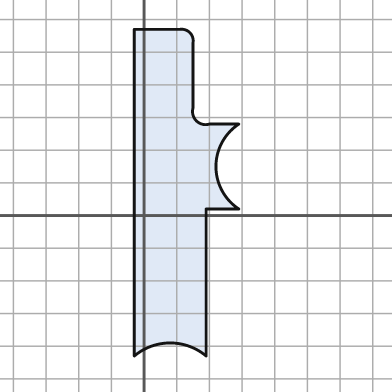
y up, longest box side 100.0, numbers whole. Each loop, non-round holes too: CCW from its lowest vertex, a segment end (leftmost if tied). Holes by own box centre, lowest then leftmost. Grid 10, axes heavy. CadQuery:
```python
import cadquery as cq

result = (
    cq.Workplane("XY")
    .moveTo(-3.0, -43.0)
    .threePointArc((8.0, -39.0), (19.0, -43.0))
    .lineTo(19.0, 2.0)
    .lineTo(29.0, 2.0)
    .threePointArc((22.0, 15.0), (29.0, 28.0))
    .lineTo(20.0, 28.0)
    .threePointArc((16.0, 29.0), (15.0, 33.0))
    .lineTo(15.0, 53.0)
    .threePointArc((14.0, 56.0), (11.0, 57.0))
    .lineTo(-3.0, 57.0)
    .close()
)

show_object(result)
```